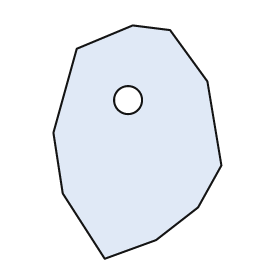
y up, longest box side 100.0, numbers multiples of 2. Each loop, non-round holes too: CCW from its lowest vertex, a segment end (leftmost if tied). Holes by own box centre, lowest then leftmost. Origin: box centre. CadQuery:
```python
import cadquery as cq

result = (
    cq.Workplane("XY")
    .moveTo(-14.0, -50.0)
    .lineTo(8.0, -42.0)
    .lineTo(26.0, -28.0)
    .lineTo(36.0, -10.0)
    .lineTo(30.0, 26.0)
    .lineTo(14.0, 48.0)
    .lineTo(-2.0, 50.0)
    .lineTo(-26.0, 40.0)
    .lineTo(-36.0, 4.0)
    .lineTo(-32.0, -22.0)
    .close()
    .moveTo(-4.0, 18.0)
    .circle(6.0)
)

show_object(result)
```